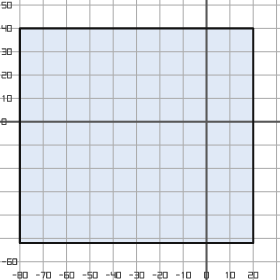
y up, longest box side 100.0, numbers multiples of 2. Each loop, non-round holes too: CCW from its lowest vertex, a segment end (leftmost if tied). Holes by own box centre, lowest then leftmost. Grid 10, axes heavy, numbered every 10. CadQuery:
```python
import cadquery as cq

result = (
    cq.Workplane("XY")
    .moveTo(-80.0, -52.0)
    .lineTo(20.0, -52.0)
    .lineTo(20.0, 40.0)
    .lineTo(-80.0, 40.0)
    .close()
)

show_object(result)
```